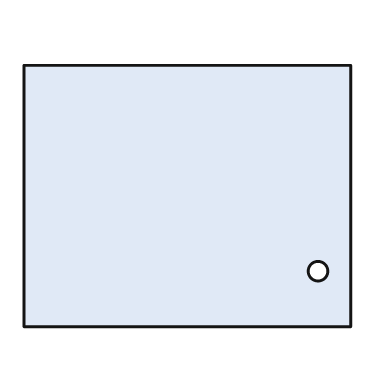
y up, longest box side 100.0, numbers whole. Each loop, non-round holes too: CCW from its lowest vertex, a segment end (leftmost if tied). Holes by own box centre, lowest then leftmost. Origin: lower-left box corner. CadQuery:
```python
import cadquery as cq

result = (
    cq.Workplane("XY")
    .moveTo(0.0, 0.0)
    .lineTo(100.0, 0.0)
    .lineTo(100.0, 80.0)
    .lineTo(0.0, 80.0)
    .close()
    .moveTo(90.0, 17.0)
    .circle(3.0)
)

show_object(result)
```